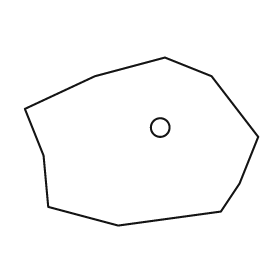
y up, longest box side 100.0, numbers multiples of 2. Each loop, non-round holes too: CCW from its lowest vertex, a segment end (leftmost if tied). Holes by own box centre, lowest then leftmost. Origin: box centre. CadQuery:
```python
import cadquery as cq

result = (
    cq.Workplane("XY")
    .moveTo(-10.0, -36.0)
    .lineTo(34.0, -30.0)
    .lineTo(42.0, -18.0)
    .lineTo(50.0, 2.0)
    .lineTo(30.0, 28.0)
    .lineTo(10.0, 36.0)
    .lineTo(-20.0, 28.0)
    .lineTo(-50.0, 14.0)
    .lineTo(-42.0, -6.0)
    .lineTo(-40.0, -28.0)
    .close()
    .moveTo(8.0, 6.0)
    .circle(4.0)
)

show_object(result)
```